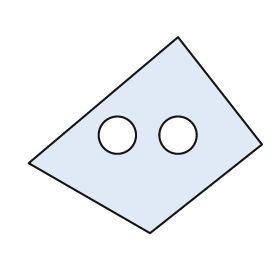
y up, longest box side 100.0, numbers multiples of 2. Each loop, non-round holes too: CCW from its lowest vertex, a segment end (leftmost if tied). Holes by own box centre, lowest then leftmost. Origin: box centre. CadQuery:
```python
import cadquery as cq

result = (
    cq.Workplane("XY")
    .moveTo(2.0, -42.0)
    .lineTo(50.0, -4.0)
    .lineTo(14.0, 42.0)
    .lineTo(-50.0, -12.0)
    .close()
    .moveTo(-12.0, 0.0)
    .circle(8.0)
    .moveTo(14.0, 0.0)
    .circle(8.0)
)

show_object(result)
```